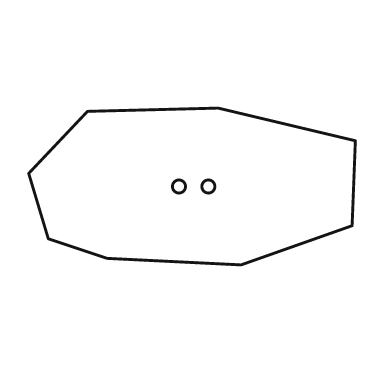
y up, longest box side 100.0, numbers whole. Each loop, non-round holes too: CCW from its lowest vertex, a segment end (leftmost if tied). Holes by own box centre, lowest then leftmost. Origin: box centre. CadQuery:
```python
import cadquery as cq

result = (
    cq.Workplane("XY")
    .moveTo(15.0, -24.0)
    .lineTo(49.0, -12.0)
    .lineTo(50.0, 14.0)
    .lineTo(8.0, 24.0)
    .lineTo(-32.0, 23.0)
    .lineTo(-50.0, 4.0)
    .lineTo(-44.0, -16.0)
    .lineTo(-26.0, -22.0)
    .close()
    .moveTo(-4.0, 0.0)
    .circle(2.0)
    .moveTo(5.0, 0.0)
    .circle(2.0)
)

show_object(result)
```